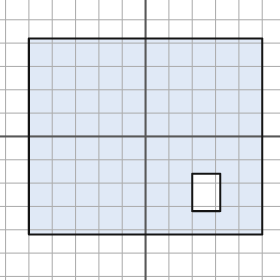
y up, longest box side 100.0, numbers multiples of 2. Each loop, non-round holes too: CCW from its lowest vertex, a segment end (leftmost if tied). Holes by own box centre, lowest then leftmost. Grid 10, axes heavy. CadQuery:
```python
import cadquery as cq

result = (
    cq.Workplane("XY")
    .moveTo(-50.0, -42.0)
    .lineTo(50.0, -42.0)
    .lineTo(50.0, 42.0)
    .lineTo(-50.0, 42.0)
    .close()
    .moveTo(20.0, -32.0)
    .lineTo(32.0, -32.0)
    .lineTo(32.0, -16.0)
    .lineTo(20.0, -16.0)
    .close()
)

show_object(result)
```